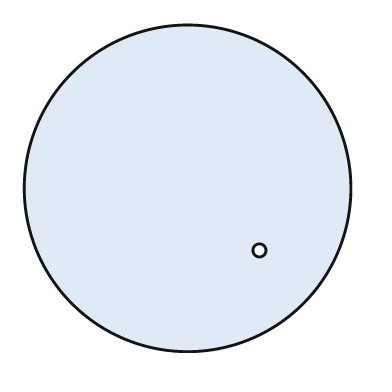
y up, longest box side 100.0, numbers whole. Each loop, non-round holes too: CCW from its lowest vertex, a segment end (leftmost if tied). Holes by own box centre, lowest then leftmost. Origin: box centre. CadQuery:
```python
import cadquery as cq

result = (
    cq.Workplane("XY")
    .moveTo(0.0, 0.0)
    .circle(50.0)
    .moveTo(22.0, -19.0)
    .circle(2.0)
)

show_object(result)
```